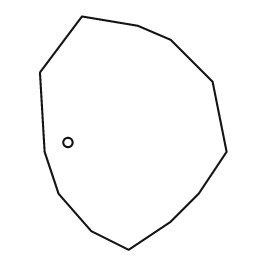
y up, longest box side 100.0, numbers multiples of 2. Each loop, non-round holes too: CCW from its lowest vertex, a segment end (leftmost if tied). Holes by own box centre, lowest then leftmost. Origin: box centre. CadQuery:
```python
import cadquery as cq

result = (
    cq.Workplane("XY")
    .moveTo(-2.0, -50.0)
    .lineTo(16.0, -38.0)
    .lineTo(28.0, -26.0)
    .lineTo(40.0, -8.0)
    .lineTo(34.0, 22.0)
    .lineTo(16.0, 40.0)
    .lineTo(2.0, 46.0)
    .lineTo(-22.0, 50.0)
    .lineTo(-40.0, 26.0)
    .lineTo(-38.0, -8.0)
    .lineTo(-32.0, -26.0)
    .lineTo(-18.0, -42.0)
    .close()
    .moveTo(-28.0, -4.0)
    .circle(2.0)
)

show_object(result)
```